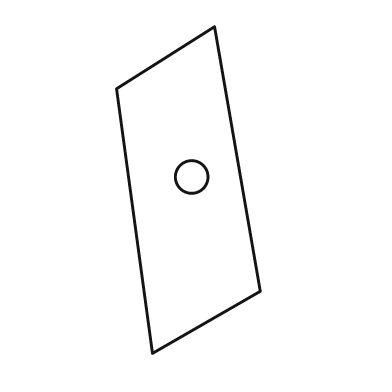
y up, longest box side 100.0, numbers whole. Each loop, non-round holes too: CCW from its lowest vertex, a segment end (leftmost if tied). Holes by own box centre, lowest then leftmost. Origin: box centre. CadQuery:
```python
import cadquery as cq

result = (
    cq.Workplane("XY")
    .moveTo(-11.0, -50.0)
    .lineTo(22.0, -31.0)
    .lineTo(8.0, 50.0)
    .lineTo(-22.0, 31.0)
    .close()
    .moveTo(1.0, 4.0)
    .circle(5.0)
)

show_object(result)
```